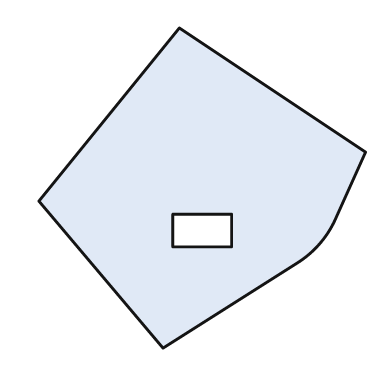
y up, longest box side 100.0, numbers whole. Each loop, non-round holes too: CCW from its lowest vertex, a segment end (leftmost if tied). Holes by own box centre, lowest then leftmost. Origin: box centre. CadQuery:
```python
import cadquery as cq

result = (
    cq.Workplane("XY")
    .moveTo(-12.0, -49.0)
    .lineTo(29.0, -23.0)
    .threePointArc((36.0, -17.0), (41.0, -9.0))
    .lineTo(50.0, 11.0)
    .lineTo(-7.0, 49.0)
    .lineTo(-50.0, -4.0)
    .close()
    .moveTo(-9.0, -18.0)
    .lineTo(9.0, -18.0)
    .lineTo(9.0, -8.0)
    .lineTo(-9.0, -8.0)
    .close()
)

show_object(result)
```